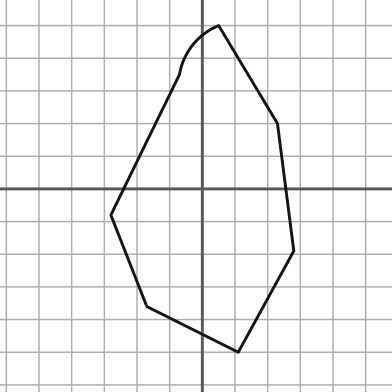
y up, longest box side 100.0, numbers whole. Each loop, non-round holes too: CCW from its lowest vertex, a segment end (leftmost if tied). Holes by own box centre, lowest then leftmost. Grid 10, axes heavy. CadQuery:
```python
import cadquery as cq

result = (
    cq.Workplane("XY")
    .moveTo(11.0, -50.0)
    .lineTo(28.0, -19.0)
    .lineTo(23.0, 20.0)
    .lineTo(5.0, 50.0)
    .threePointArc((-3.0, 44.0), (-7.0, 35.0))
    .lineTo(-28.0, -8.0)
    .lineTo(-17.0, -36.0)
    .close()
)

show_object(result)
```